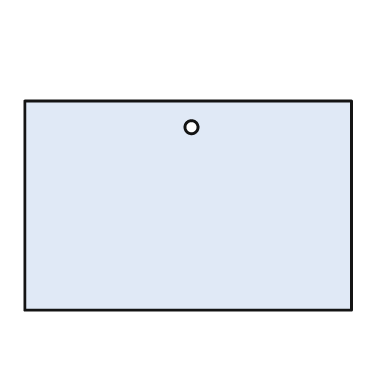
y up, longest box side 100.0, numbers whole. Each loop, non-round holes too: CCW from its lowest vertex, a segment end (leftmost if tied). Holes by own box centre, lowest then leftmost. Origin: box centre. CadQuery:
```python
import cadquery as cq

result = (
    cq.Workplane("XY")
    .moveTo(-50.0, -32.0)
    .lineTo(50.0, -32.0)
    .lineTo(50.0, 32.0)
    .lineTo(-50.0, 32.0)
    .close()
    .moveTo(1.0, 24.0)
    .circle(2.0)
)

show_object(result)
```